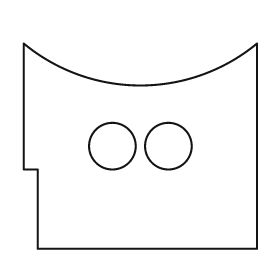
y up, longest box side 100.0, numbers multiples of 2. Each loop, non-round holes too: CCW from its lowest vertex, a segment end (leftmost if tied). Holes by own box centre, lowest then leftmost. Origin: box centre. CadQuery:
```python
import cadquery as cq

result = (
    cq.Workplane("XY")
    .moveTo(-44.0, -44.0)
    .lineTo(50.0, -44.0)
    .lineTo(50.0, 44.0)
    .threePointArc((0.0, 26.0), (-50.0, 44.0))
    .lineTo(-50.0, -10.0)
    .lineTo(-44.0, -10.0)
    .close()
    .moveTo(-12.0, 0.0)
    .circle(10.0)
    .moveTo(12.0, 0.0)
    .circle(10.0)
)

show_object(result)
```